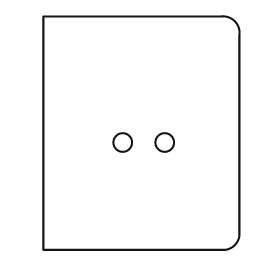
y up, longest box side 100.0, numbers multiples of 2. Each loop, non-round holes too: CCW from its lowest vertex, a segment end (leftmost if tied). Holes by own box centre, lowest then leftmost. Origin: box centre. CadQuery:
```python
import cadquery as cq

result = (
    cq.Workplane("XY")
    .moveTo(-42.0, -50.0)
    .lineTo(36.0, -50.0)
    .threePointArc((40.0, -48.0), (42.0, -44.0))
    .lineTo(42.0, 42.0)
    .threePointArc((40.0, 48.0), (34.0, 50.0))
    .lineTo(-42.0, 50.0)
    .close()
    .moveTo(-8.0, -4.0)
    .circle(4.0)
    .moveTo(10.0, -4.0)
    .circle(4.0)
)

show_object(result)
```